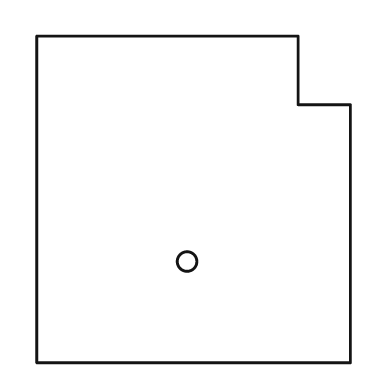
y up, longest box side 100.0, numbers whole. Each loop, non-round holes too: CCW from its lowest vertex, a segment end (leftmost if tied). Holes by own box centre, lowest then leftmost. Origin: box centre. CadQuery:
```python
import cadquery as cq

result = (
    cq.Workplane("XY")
    .moveTo(-48.0, -50.0)
    .lineTo(48.0, -50.0)
    .lineTo(48.0, 29.0)
    .lineTo(32.0, 29.0)
    .lineTo(32.0, 50.0)
    .lineTo(-48.0, 50.0)
    .close()
    .moveTo(-2.0, -19.0)
    .circle(3.0)
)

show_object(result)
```